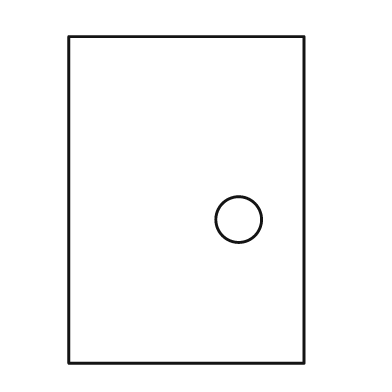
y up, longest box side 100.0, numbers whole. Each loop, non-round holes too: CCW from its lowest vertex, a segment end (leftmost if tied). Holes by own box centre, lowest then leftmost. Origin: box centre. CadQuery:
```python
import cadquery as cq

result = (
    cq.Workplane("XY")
    .moveTo(-36.0, -50.0)
    .lineTo(36.0, -50.0)
    .lineTo(36.0, 50.0)
    .lineTo(-36.0, 50.0)
    .close()
    .moveTo(16.0, -6.0)
    .circle(7.0)
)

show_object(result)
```